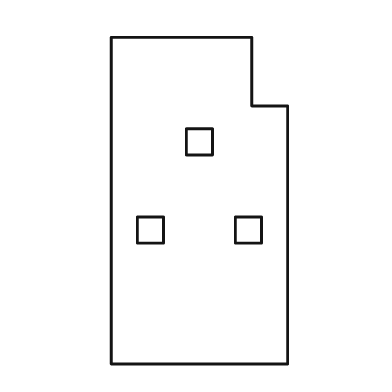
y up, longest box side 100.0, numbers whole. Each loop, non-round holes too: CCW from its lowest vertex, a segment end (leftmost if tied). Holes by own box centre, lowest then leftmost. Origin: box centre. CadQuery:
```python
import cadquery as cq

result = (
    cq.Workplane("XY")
    .moveTo(-27.0, -50.0)
    .lineTo(27.0, -50.0)
    .lineTo(27.0, 29.0)
    .lineTo(16.0, 29.0)
    .lineTo(16.0, 50.0)
    .lineTo(-27.0, 50.0)
    .close()
    .moveTo(-19.0, -13.0)
    .lineTo(-11.0, -13.0)
    .lineTo(-11.0, -5.0)
    .lineTo(-19.0, -5.0)
    .close()
    .moveTo(11.0, -13.0)
    .lineTo(19.0, -13.0)
    .lineTo(19.0, -5.0)
    .lineTo(11.0, -5.0)
    .close()
    .moveTo(-4.0, 14.0)
    .lineTo(4.0, 14.0)
    .lineTo(4.0, 22.0)
    .lineTo(-4.0, 22.0)
    .close()
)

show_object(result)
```